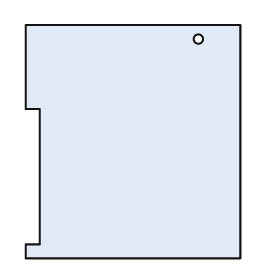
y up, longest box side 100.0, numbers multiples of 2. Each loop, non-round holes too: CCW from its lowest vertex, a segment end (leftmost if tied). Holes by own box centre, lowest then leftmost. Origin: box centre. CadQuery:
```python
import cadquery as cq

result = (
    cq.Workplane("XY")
    .moveTo(-46.0, -50.0)
    .lineTo(46.0, -50.0)
    .lineTo(46.0, 50.0)
    .lineTo(-46.0, 50.0)
    .lineTo(-46.0, 14.0)
    .lineTo(-40.0, 14.0)
    .lineTo(-40.0, -44.0)
    .lineTo(-46.0, -44.0)
    .close()
    .moveTo(28.0, 44.0)
    .circle(2.0)
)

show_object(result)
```